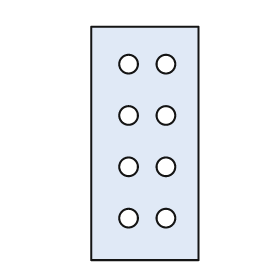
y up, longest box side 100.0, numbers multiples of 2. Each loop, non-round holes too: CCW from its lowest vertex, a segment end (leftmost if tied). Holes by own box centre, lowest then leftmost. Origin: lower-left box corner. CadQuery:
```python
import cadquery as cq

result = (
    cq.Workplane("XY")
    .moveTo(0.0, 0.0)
    .lineTo(46.0, 0.0)
    .lineTo(46.0, 100.0)
    .lineTo(0.0, 100.0)
    .close()
    .moveTo(16.0, 18.0)
    .circle(4.0)
    .moveTo(32.0, 18.0)
    .circle(4.0)
    .moveTo(16.0, 40.0)
    .circle(4.0)
    .moveTo(32.0, 40.0)
    .circle(4.0)
    .moveTo(16.0, 62.0)
    .circle(4.0)
    .moveTo(32.0, 62.0)
    .circle(4.0)
    .moveTo(16.0, 84.0)
    .circle(4.0)
    .moveTo(32.0, 84.0)
    .circle(4.0)
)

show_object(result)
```